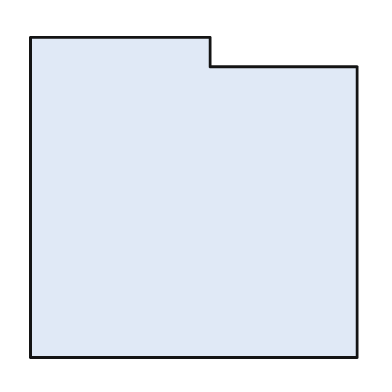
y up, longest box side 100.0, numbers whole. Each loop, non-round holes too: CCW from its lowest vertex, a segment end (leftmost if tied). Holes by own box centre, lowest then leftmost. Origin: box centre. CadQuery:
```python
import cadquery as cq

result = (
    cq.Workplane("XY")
    .moveTo(-50.0, -49.0)
    .lineTo(50.0, -49.0)
    .lineTo(50.0, 40.0)
    .lineTo(5.0, 40.0)
    .lineTo(5.0, 49.0)
    .lineTo(-50.0, 49.0)
    .close()
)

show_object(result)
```